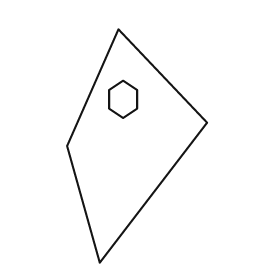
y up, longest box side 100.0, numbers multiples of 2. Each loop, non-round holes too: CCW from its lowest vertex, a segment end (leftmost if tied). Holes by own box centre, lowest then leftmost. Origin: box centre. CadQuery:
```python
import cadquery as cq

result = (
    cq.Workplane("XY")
    .moveTo(-16.0, -50.0)
    .lineTo(30.0, 10.0)
    .lineTo(-8.0, 50.0)
    .lineTo(-30.0, 0.0)
    .close()
    .moveTo(-6.0, 12.0)
    .lineTo(0.0, 16.0)
    .lineTo(0.0, 24.0)
    .lineTo(-6.0, 28.0)
    .lineTo(-12.0, 24.0)
    .lineTo(-12.0, 16.0)
    .close()
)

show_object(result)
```